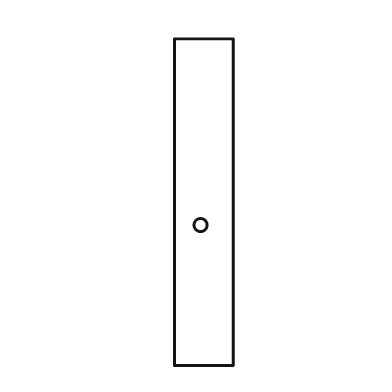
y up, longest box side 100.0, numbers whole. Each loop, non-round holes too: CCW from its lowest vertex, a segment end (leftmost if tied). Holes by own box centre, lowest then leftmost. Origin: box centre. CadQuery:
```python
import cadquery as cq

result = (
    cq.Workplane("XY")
    .moveTo(-9.0, -50.0)
    .lineTo(9.0, -50.0)
    .lineTo(9.0, 50.0)
    .lineTo(-9.0, 50.0)
    .close()
    .moveTo(-1.0, -7.0)
    .circle(2.0)
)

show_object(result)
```